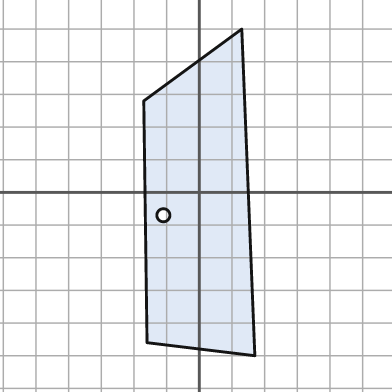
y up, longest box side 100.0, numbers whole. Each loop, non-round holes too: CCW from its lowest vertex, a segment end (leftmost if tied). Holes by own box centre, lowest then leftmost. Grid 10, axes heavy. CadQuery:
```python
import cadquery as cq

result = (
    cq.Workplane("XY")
    .moveTo(17.0, -50.0)
    .lineTo(13.0, 50.0)
    .lineTo(-17.0, 28.0)
    .lineTo(-16.0, -46.0)
    .close()
    .moveTo(-11.0, -7.0)
    .circle(2.0)
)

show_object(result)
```